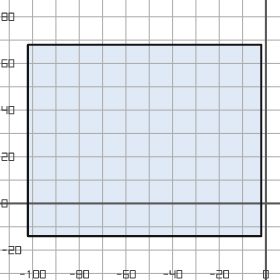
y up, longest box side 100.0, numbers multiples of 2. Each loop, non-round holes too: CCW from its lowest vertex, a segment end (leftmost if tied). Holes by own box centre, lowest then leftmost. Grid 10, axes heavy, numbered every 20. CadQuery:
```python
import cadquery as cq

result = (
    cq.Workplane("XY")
    .moveTo(-102.0, -14.0)
    .lineTo(-2.0, -14.0)
    .lineTo(-2.0, 68.0)
    .lineTo(-102.0, 68.0)
    .close()
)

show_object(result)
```